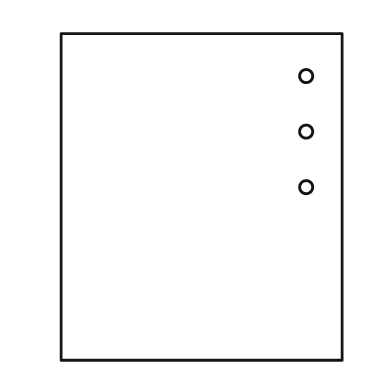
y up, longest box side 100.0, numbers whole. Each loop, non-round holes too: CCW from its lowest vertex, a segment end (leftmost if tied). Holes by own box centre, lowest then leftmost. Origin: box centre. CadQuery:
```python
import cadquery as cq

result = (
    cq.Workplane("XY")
    .moveTo(-43.0, -50.0)
    .lineTo(43.0, -50.0)
    .lineTo(43.0, 50.0)
    .lineTo(-43.0, 50.0)
    .close()
    .moveTo(32.0, 3.0)
    .circle(2.0)
    .moveTo(32.0, 20.0)
    .circle(2.0)
    .moveTo(32.0, 37.0)
    .circle(2.0)
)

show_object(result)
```